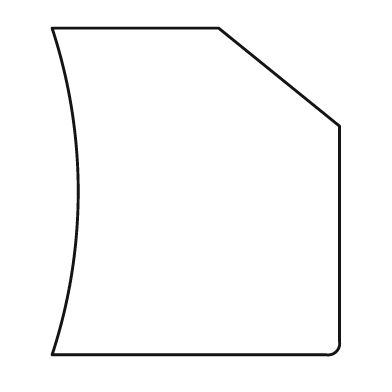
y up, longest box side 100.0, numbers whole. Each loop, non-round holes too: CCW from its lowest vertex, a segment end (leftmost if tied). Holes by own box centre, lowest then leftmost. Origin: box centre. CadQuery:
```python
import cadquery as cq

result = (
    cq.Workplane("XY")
    .moveTo(-44.0, -50.0)
    .lineTo(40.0, -50.0)
    .threePointArc((43.0, -49.0), (44.0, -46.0))
    .lineTo(44.0, 20.0)
    .lineTo(7.0, 50.0)
    .lineTo(-44.0, 50.0)
    .threePointArc((-36.0, 0.0), (-44.0, -50.0))
    .close()
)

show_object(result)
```